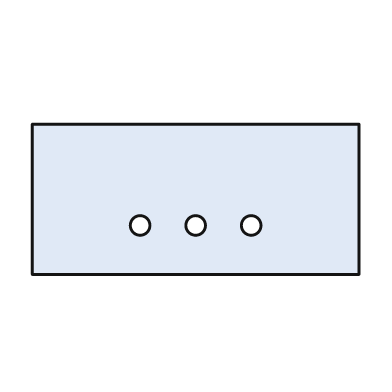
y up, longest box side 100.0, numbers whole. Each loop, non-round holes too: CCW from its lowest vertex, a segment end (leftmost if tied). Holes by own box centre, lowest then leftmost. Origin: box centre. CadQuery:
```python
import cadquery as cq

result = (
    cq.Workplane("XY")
    .moveTo(-50.0, -23.0)
    .lineTo(50.0, -23.0)
    .lineTo(50.0, 23.0)
    .lineTo(-50.0, 23.0)
    .close()
    .moveTo(-17.0, -8.0)
    .circle(3.0)
    .moveTo(0.0, -8.0)
    .circle(3.0)
    .moveTo(17.0, -8.0)
    .circle(3.0)
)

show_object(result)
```